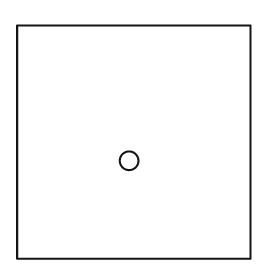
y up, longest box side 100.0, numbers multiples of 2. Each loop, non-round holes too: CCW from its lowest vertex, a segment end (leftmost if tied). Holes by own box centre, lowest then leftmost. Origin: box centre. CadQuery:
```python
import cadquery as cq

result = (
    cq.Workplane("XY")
    .moveTo(-50.0, -50.0)
    .lineTo(50.0, -50.0)
    .lineTo(50.0, 50.0)
    .lineTo(-50.0, 50.0)
    .close()
    .moveTo(-2.0, -8.0)
    .circle(4.0)
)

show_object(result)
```